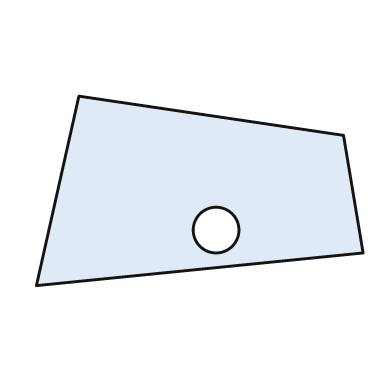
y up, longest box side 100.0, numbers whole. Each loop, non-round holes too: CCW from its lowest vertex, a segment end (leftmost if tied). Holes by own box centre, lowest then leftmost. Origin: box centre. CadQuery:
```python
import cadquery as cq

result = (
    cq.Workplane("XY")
    .moveTo(-50.0, -29.0)
    .lineTo(50.0, -19.0)
    .lineTo(44.0, 17.0)
    .lineTo(-37.0, 29.0)
    .close()
    .moveTo(5.0, -12.0)
    .circle(7.0)
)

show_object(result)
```